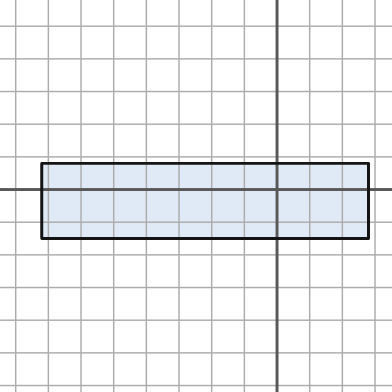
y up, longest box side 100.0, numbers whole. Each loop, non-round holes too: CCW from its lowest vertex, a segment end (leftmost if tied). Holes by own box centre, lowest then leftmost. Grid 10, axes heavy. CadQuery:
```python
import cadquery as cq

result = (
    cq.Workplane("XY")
    .moveTo(-72.0, -15.0)
    .lineTo(28.0, -15.0)
    .lineTo(28.0, 8.0)
    .lineTo(-72.0, 8.0)
    .close()
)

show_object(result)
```